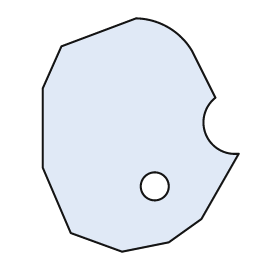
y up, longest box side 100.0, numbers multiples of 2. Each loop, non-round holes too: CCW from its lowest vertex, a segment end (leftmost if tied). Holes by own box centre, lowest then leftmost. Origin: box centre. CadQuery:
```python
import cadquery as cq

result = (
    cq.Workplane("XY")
    .moveTo(-8.0, -50.0)
    .lineTo(12.0, -46.0)
    .lineTo(26.0, -36.0)
    .lineTo(42.0, -8.0)
    .threePointArc((28.0, 0.0), (32.0, 16.0))
    .lineTo(22.0, 36.0)
    .threePointArc((12.0, 46.0), (-2.0, 50.0))
    .lineTo(-34.0, 38.0)
    .lineTo(-42.0, 20.0)
    .lineTo(-42.0, -14.0)
    .lineTo(-30.0, -42.0)
    .close()
    .moveTo(6.0, -22.0)
    .circle(6.0)
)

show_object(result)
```